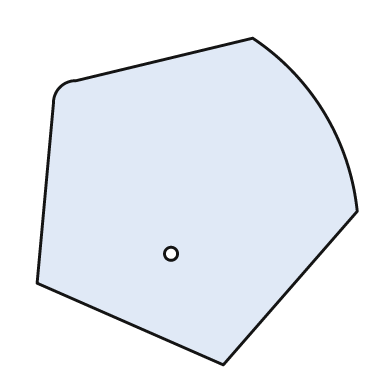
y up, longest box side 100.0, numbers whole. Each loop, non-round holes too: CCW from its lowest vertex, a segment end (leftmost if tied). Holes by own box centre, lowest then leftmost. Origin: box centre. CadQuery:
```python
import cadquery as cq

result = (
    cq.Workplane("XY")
    .moveTo(8.0, -50.0)
    .lineTo(49.0, -3.0)
    .threePointArc((39.0, 27.0), (17.0, 50.0))
    .lineTo(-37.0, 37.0)
    .threePointArc((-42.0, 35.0), (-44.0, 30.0))
    .lineTo(-49.0, -25.0)
    .close()
    .moveTo(-8.0, -16.0)
    .circle(2.0)
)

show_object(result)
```